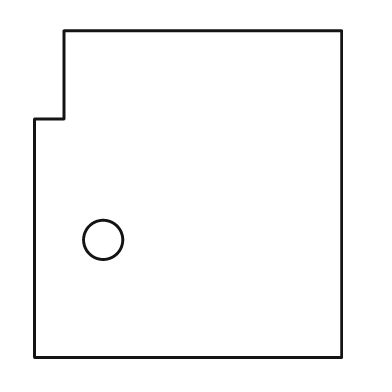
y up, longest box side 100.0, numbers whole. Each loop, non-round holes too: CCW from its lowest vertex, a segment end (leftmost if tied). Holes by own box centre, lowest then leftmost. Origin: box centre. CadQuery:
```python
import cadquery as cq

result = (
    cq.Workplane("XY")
    .moveTo(-47.0, -50.0)
    .lineTo(47.0, -50.0)
    .lineTo(47.0, 50.0)
    .lineTo(-38.0, 50.0)
    .lineTo(-38.0, 23.0)
    .lineTo(-47.0, 23.0)
    .close()
    .moveTo(-26.0, -14.0)
    .circle(6.0)
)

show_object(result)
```